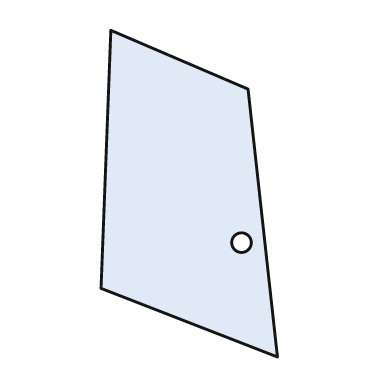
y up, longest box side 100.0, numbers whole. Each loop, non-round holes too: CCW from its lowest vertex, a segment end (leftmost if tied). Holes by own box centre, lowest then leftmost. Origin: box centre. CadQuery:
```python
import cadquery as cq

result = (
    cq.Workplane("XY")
    .moveTo(27.0, -50.0)
    .lineTo(18.0, 32.0)
    .lineTo(-24.0, 50.0)
    .lineTo(-27.0, -29.0)
    .close()
    .moveTo(16.0, -15.0)
    .circle(3.0)
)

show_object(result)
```